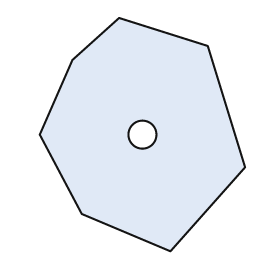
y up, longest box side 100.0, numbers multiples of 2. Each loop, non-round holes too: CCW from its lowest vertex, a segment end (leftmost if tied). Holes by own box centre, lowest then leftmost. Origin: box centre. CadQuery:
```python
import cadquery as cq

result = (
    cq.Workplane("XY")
    .moveTo(12.0, -50.0)
    .lineTo(44.0, -14.0)
    .lineTo(28.0, 38.0)
    .lineTo(-10.0, 50.0)
    .lineTo(-30.0, 32.0)
    .lineTo(-44.0, 0.0)
    .lineTo(-26.0, -34.0)
    .close()
    .moveTo(0.0, 0.0)
    .circle(6.0)
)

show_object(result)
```